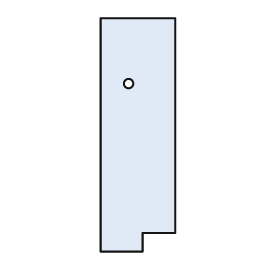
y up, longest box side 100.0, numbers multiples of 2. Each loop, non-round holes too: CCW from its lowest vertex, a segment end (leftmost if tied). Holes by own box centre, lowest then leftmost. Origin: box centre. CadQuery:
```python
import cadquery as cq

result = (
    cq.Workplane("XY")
    .moveTo(-16.0, -50.0)
    .lineTo(2.0, -50.0)
    .lineTo(2.0, -42.0)
    .lineTo(16.0, -42.0)
    .lineTo(16.0, 50.0)
    .lineTo(-16.0, 50.0)
    .close()
    .moveTo(-4.0, 22.0)
    .circle(2.0)
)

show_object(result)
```